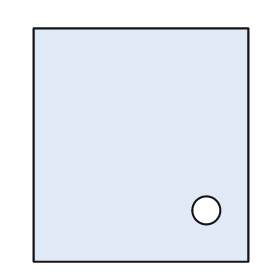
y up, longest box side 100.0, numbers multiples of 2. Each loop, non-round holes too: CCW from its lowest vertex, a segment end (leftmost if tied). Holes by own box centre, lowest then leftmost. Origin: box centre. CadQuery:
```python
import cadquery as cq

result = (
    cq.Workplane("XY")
    .moveTo(-46.0, -50.0)
    .lineTo(46.0, -50.0)
    .lineTo(46.0, 50.0)
    .lineTo(-46.0, 50.0)
    .close()
    .moveTo(28.0, -28.0)
    .circle(6.0)
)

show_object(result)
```